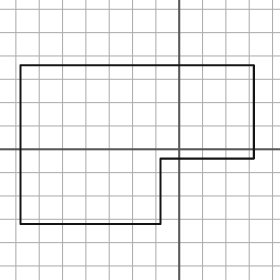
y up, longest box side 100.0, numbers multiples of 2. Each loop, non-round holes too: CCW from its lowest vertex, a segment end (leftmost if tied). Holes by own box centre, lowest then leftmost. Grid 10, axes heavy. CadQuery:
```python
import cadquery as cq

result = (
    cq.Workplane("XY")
    .moveTo(-68.0, -32.0)
    .lineTo(-8.0, -32.0)
    .lineTo(-8.0, -4.0)
    .lineTo(32.0, -4.0)
    .lineTo(32.0, 36.0)
    .lineTo(-68.0, 36.0)
    .close()
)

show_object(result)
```